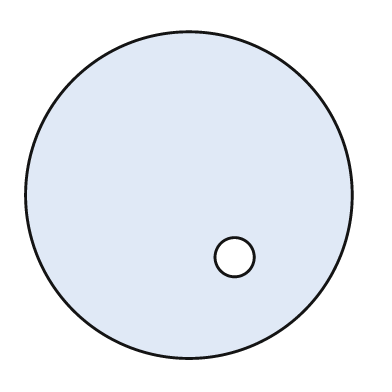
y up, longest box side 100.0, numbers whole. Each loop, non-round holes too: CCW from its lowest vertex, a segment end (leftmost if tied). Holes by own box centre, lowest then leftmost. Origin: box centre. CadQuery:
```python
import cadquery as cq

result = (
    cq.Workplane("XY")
    .moveTo(0.0, 0.0)
    .circle(50.0)
    .moveTo(14.0, -19.0)
    .circle(6.0)
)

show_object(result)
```